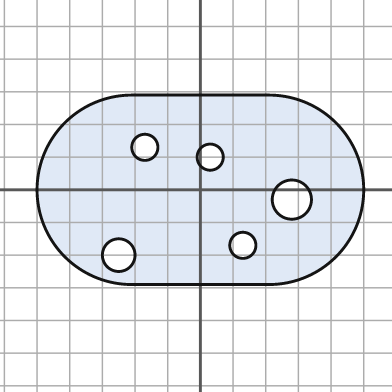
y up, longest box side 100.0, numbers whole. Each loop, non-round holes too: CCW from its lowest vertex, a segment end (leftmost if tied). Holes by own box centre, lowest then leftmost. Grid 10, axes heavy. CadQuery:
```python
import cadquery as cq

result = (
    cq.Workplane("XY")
    .moveTo(-21.0, -29.0)
    .lineTo(21.0, -29.0)
    .threePointArc((50.0, 0.0), (21.0, 29.0))
    .lineTo(-21.0, 29.0)
    .threePointArc((-50.0, 0.0), (-21.0, -29.0))
    .close()
    .moveTo(-25.0, -20.0)
    .circle(5.0)
    .moveTo(13.0, -17.0)
    .circle(4.0)
    .moveTo(28.0, -3.0)
    .circle(6.0)
    .moveTo(3.0, 10.0)
    .circle(4.0)
    .moveTo(-17.0, 13.0)
    .circle(4.0)
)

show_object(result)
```